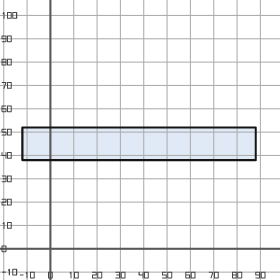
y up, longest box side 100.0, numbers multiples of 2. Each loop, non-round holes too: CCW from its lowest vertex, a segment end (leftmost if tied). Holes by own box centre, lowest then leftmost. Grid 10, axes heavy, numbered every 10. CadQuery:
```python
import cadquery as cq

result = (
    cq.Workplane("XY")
    .moveTo(-12.0, 38.0)
    .lineTo(88.0, 38.0)
    .lineTo(88.0, 52.0)
    .lineTo(-12.0, 52.0)
    .close()
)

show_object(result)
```